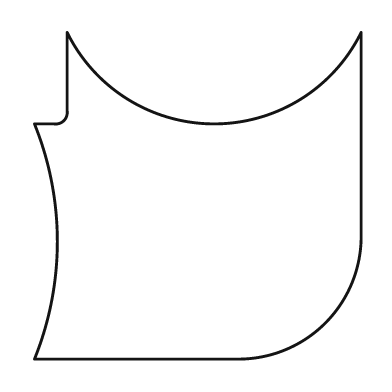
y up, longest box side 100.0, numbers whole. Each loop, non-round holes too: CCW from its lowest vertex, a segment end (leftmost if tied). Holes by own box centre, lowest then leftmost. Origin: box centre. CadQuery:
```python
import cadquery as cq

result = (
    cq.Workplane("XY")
    .moveTo(-50.0, -50.0)
    .lineTo(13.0, -50.0)
    .threePointArc((39.0, -39.0), (50.0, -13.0))
    .lineTo(50.0, 50.0)
    .threePointArc((5.0, 22.0), (-40.0, 50.0))
    .lineTo(-40.0, 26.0)
    .threePointArc((-41.0, 23.0), (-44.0, 22.0))
    .lineTo(-50.0, 22.0)
    .threePointArc((-43.0, -14.0), (-50.0, -50.0))
    .close()
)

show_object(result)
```